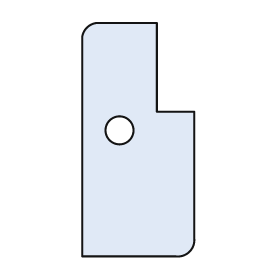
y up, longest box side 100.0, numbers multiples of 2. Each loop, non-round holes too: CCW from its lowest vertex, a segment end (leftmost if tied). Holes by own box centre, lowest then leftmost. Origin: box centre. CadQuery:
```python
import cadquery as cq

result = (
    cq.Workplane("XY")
    .moveTo(-24.0, -50.0)
    .lineTo(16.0, -50.0)
    .threePointArc((22.0, -48.0), (24.0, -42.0))
    .lineTo(24.0, 12.0)
    .lineTo(8.0, 12.0)
    .lineTo(8.0, 50.0)
    .lineTo(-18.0, 50.0)
    .threePointArc((-22.0, 48.0), (-24.0, 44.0))
    .close()
    .moveTo(-8.0, 4.0)
    .circle(6.0)
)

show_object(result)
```